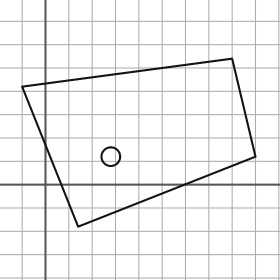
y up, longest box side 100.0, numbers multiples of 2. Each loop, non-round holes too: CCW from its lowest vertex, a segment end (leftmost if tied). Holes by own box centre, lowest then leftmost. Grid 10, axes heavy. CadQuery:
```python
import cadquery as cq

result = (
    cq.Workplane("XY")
    .moveTo(14.0, -18.0)
    .lineTo(90.0, 12.0)
    .lineTo(80.0, 54.0)
    .lineTo(-10.0, 42.0)
    .close()
    .moveTo(28.0, 12.0)
    .circle(4.0)
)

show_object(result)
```